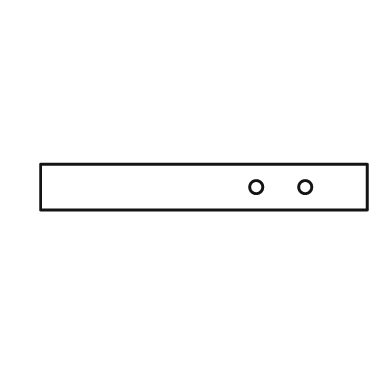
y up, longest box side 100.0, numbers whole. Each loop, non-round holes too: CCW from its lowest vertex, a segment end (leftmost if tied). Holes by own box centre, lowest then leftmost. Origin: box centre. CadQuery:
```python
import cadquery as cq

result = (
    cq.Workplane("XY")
    .moveTo(-50.0, -7.0)
    .lineTo(50.0, -7.0)
    .lineTo(50.0, 7.0)
    .lineTo(-50.0, 7.0)
    .close()
    .moveTo(16.0, 0.0)
    .circle(2.0)
    .moveTo(31.0, 0.0)
    .circle(2.0)
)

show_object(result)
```